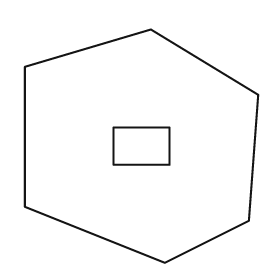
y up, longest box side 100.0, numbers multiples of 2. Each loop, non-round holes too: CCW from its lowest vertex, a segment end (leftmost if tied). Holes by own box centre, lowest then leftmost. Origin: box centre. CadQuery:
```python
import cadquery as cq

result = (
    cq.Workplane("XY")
    .moveTo(10.0, -50.0)
    .lineTo(46.0, -32.0)
    .lineTo(50.0, 22.0)
    .lineTo(4.0, 50.0)
    .lineTo(-50.0, 34.0)
    .lineTo(-50.0, -26.0)
    .close()
    .moveTo(-12.0, -8.0)
    .lineTo(12.0, -8.0)
    .lineTo(12.0, 8.0)
    .lineTo(-12.0, 8.0)
    .close()
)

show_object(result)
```